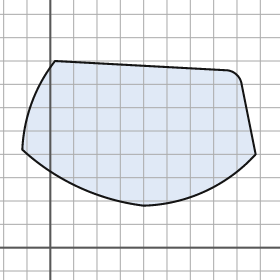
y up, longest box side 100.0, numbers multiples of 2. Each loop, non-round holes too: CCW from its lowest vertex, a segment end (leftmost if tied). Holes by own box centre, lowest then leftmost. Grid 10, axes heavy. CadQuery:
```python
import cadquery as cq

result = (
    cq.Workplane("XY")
    .moveTo(40.0, 18.0)
    .threePointArc((66.0, 24.0), (88.0, 40.0))
    .lineTo(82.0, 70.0)
    .threePointArc((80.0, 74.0), (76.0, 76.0))
    .lineTo(2.0, 80.0)
    .threePointArc((-8.0, 62.0), (-12.0, 42.0))
    .threePointArc((12.0, 26.0), (40.0, 18.0))
    .close()
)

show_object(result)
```